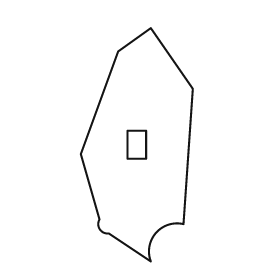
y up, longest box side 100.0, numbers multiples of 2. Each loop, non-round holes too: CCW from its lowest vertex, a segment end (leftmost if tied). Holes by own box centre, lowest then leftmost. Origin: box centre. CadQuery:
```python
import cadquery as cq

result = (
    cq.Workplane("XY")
    .moveTo(6.0, -50.0)
    .threePointArc((8.0, -38.0), (20.0, -34.0))
    .lineTo(24.0, 24.0)
    .lineTo(6.0, 50.0)
    .lineTo(-8.0, 40.0)
    .lineTo(-24.0, -4.0)
    .lineTo(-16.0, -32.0)
    .threePointArc((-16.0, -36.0), (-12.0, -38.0))
    .close()
    .moveTo(-4.0, -6.0)
    .lineTo(4.0, -6.0)
    .lineTo(4.0, 6.0)
    .lineTo(-4.0, 6.0)
    .close()
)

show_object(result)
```